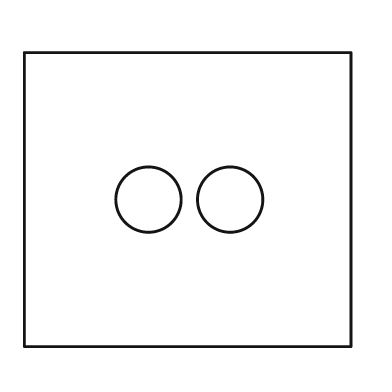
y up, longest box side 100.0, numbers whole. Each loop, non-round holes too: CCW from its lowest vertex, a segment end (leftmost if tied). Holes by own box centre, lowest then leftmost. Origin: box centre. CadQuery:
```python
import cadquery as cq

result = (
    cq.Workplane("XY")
    .moveTo(-50.0, -45.0)
    .lineTo(50.0, -45.0)
    .lineTo(50.0, 45.0)
    .lineTo(-50.0, 45.0)
    .close()
    .moveTo(-12.0, 0.0)
    .circle(10.0)
    .moveTo(13.0, 0.0)
    .circle(10.0)
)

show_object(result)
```